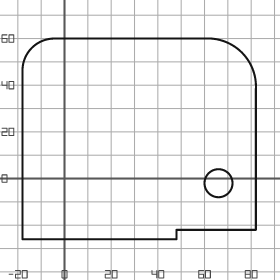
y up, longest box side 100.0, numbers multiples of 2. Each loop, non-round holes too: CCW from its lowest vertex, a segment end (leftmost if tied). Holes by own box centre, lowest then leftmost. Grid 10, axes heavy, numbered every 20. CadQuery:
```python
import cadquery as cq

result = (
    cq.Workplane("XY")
    .moveTo(-18.0, -26.0)
    .lineTo(48.0, -26.0)
    .lineTo(48.0, -22.0)
    .lineTo(82.0, -22.0)
    .lineTo(82.0, 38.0)
    .threePointArc((76.0, 54.0), (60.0, 60.0))
    .lineTo(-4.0, 60.0)
    .threePointArc((-14.0, 56.0), (-18.0, 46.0))
    .close()
    .moveTo(66.0, -2.0)
    .circle(6.0)
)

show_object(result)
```